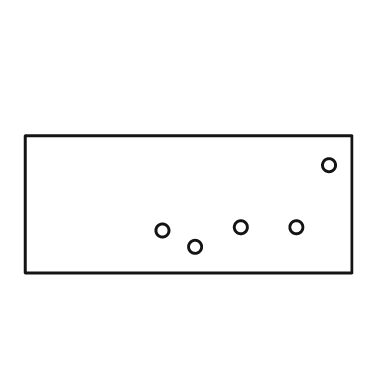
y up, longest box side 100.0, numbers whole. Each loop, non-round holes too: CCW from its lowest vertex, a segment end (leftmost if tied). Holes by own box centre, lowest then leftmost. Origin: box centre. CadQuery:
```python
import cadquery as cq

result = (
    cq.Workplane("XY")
    .moveTo(-50.0, -21.0)
    .lineTo(50.0, -21.0)
    .lineTo(50.0, 21.0)
    .lineTo(-50.0, 21.0)
    .close()
    .moveTo(2.0, -13.0)
    .circle(2.0)
    .moveTo(-8.0, -8.0)
    .circle(2.0)
    .moveTo(16.0, -7.0)
    .circle(2.0)
    .moveTo(33.0, -7.0)
    .circle(2.0)
    .moveTo(43.0, 12.0)
    .circle(2.0)
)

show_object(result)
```